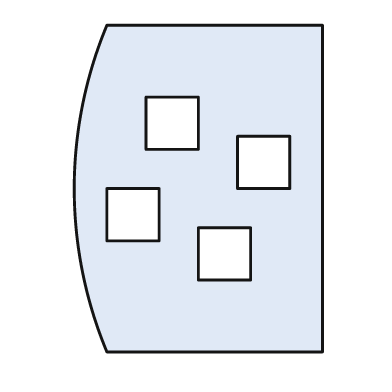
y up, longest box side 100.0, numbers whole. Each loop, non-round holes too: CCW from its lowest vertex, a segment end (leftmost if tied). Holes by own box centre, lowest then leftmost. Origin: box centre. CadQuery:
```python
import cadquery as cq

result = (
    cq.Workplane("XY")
    .moveTo(-28.0, -50.0)
    .lineTo(38.0, -50.0)
    .lineTo(38.0, 50.0)
    .lineTo(-28.0, 50.0)
    .threePointArc((-38.0, 0.0), (-28.0, -50.0))
    .close()
    .moveTo(0.0, -28.0)
    .lineTo(16.0, -28.0)
    .lineTo(16.0, -12.0)
    .lineTo(0.0, -12.0)
    .close()
    .moveTo(-28.0, -16.0)
    .lineTo(-12.0, -16.0)
    .lineTo(-12.0, 0.0)
    .lineTo(-28.0, 0.0)
    .close()
    .moveTo(12.0, 0.0)
    .lineTo(28.0, 0.0)
    .lineTo(28.0, 16.0)
    .lineTo(12.0, 16.0)
    .close()
    .moveTo(-16.0, 12.0)
    .lineTo(0.0, 12.0)
    .lineTo(0.0, 28.0)
    .lineTo(-16.0, 28.0)
    .close()
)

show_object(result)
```